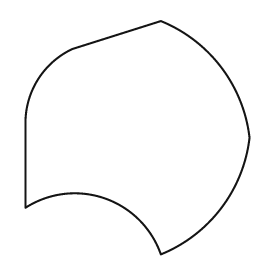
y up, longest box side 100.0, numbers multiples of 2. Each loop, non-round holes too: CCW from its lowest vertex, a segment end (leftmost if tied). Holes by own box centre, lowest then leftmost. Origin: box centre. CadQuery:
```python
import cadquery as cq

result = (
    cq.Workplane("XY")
    .moveTo(10.0, -50.0)
    .threePointArc((36.0, -30.0), (48.0, 0.0))
    .threePointArc((36.0, 30.0), (10.0, 50.0))
    .lineTo(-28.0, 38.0)
    .threePointArc((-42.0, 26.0), (-48.0, 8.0))
    .lineTo(-48.0, -30.0)
    .threePointArc((-14.0, -26.0), (10.0, -50.0))
    .close()
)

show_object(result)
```